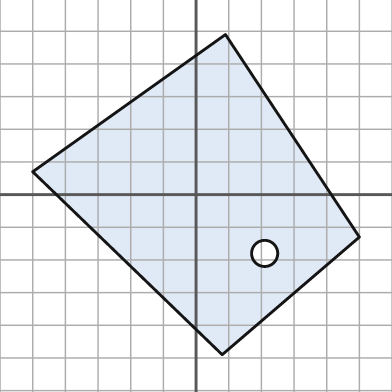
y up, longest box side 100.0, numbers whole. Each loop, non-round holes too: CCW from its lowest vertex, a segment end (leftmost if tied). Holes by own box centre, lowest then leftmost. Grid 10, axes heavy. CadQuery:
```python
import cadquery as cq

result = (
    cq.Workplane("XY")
    .moveTo(8.0, -49.0)
    .lineTo(50.0, -13.0)
    .lineTo(9.0, 49.0)
    .lineTo(-50.0, 7.0)
    .close()
    .moveTo(21.0, -18.0)
    .circle(4.0)
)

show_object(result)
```